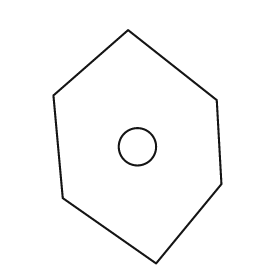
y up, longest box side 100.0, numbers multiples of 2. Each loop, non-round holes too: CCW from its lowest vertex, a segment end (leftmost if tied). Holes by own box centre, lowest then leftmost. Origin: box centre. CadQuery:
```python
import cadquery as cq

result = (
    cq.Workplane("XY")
    .moveTo(8.0, -50.0)
    .lineTo(36.0, -16.0)
    .lineTo(34.0, 20.0)
    .lineTo(-4.0, 50.0)
    .lineTo(-36.0, 22.0)
    .lineTo(-32.0, -22.0)
    .close()
    .moveTo(0.0, 0.0)
    .circle(8.0)
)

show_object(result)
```